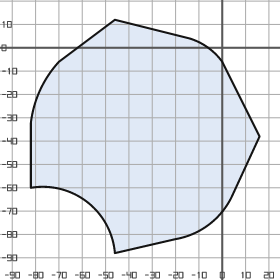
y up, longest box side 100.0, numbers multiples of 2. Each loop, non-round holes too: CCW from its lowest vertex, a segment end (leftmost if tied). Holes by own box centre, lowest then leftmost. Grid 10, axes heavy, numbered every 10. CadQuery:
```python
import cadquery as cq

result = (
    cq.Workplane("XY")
    .moveTo(-46.0, -88.0)
    .lineTo(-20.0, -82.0)
    .threePointArc((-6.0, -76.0), (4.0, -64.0))
    .lineTo(16.0, -38.0)
    .lineTo(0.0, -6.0)
    .threePointArc((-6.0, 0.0), (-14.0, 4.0))
    .lineTo(-46.0, 12.0)
    .lineTo(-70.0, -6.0)
    .threePointArc((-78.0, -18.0), (-82.0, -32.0))
    .lineTo(-82.0, -60.0)
    .threePointArc((-58.0, -66.0), (-46.0, -88.0))
    .close()
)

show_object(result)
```